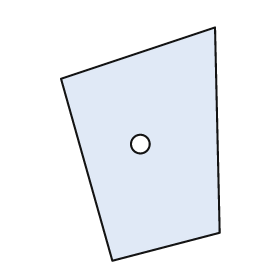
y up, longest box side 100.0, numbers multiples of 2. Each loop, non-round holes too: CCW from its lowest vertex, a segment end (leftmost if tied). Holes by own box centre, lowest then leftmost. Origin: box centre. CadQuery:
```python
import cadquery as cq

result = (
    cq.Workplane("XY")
    .moveTo(-12.0, -50.0)
    .lineTo(34.0, -38.0)
    .lineTo(32.0, 50.0)
    .lineTo(-34.0, 28.0)
    .close()
    .moveTo(0.0, 0.0)
    .circle(4.0)
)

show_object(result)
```